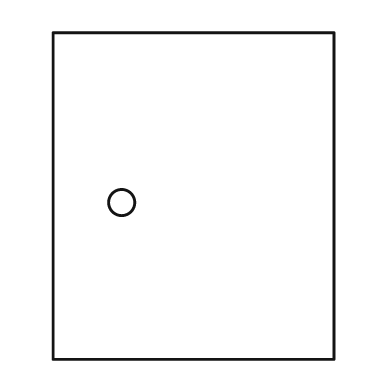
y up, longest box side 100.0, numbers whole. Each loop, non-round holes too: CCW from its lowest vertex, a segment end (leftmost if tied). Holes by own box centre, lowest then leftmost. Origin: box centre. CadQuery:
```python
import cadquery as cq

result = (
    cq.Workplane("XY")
    .moveTo(-43.0, -50.0)
    .lineTo(43.0, -50.0)
    .lineTo(43.0, 50.0)
    .lineTo(-43.0, 50.0)
    .close()
    .moveTo(-22.0, -2.0)
    .circle(4.0)
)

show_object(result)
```